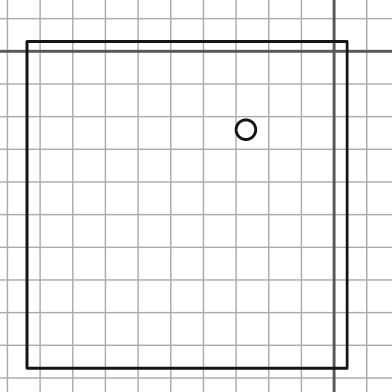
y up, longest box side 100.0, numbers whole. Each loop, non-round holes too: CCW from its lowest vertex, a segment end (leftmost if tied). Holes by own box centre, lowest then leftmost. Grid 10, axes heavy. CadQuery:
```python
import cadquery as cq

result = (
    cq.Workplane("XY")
    .moveTo(-94.0, -97.0)
    .lineTo(4.0, -97.0)
    .lineTo(4.0, 3.0)
    .lineTo(-94.0, 3.0)
    .close()
    .moveTo(-27.0, -24.0)
    .circle(3.0)
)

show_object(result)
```